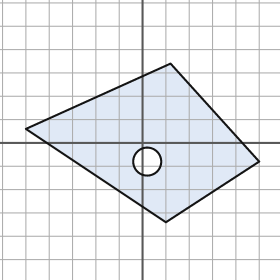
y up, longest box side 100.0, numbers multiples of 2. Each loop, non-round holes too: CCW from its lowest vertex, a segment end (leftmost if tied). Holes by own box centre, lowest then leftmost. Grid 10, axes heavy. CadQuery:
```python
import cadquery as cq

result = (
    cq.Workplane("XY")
    .moveTo(10.0, -34.0)
    .lineTo(50.0, -8.0)
    .lineTo(12.0, 34.0)
    .lineTo(-50.0, 6.0)
    .close()
    .moveTo(2.0, -8.0)
    .circle(6.0)
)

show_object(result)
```